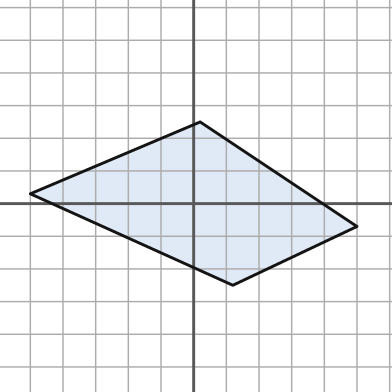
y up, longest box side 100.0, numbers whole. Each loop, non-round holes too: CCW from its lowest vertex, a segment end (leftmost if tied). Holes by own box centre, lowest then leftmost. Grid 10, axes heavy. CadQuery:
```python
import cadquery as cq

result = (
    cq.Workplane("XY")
    .moveTo(12.0, -25.0)
    .lineTo(50.0, -7.0)
    .lineTo(2.0, 25.0)
    .lineTo(-50.0, 3.0)
    .close()
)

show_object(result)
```